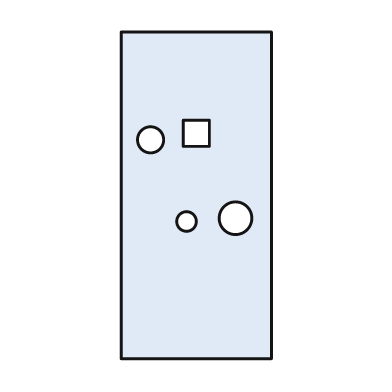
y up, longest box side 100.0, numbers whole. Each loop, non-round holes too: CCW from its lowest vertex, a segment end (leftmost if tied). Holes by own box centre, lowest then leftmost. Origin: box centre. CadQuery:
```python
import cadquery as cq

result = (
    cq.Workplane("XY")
    .moveTo(-23.0, -50.0)
    .lineTo(23.0, -50.0)
    .lineTo(23.0, 50.0)
    .lineTo(-23.0, 50.0)
    .close()
    .moveTo(-3.0, -8.0)
    .circle(3.0)
    .moveTo(12.0, -7.0)
    .circle(5.0)
    .moveTo(-14.0, 17.0)
    .circle(4.0)
    .moveTo(-4.0, 15.0)
    .lineTo(4.0, 15.0)
    .lineTo(4.0, 23.0)
    .lineTo(-4.0, 23.0)
    .close()
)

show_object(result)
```